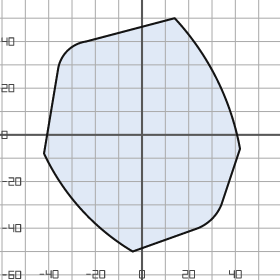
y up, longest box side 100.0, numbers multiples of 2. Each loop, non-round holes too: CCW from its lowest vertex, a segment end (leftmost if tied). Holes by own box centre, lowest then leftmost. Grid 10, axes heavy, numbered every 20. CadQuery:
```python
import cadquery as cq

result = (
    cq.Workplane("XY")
    .moveTo(-4.0, -50.0)
    .lineTo(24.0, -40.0)
    .threePointArc((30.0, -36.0), (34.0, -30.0))
    .lineTo(42.0, -6.0)
    .threePointArc((32.0, 24.0), (14.0, 50.0))
    .lineTo(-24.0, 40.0)
    .threePointArc((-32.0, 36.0), (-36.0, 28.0))
    .lineTo(-42.0, -8.0)
    .threePointArc((-26.0, -32.0), (-4.0, -50.0))
    .close()
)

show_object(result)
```